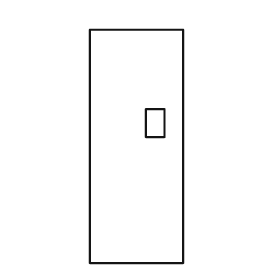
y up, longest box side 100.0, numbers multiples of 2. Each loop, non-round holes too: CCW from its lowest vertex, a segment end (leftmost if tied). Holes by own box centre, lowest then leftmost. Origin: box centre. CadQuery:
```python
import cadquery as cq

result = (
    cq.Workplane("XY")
    .moveTo(-20.0, -50.0)
    .lineTo(20.0, -50.0)
    .lineTo(20.0, 50.0)
    .lineTo(-20.0, 50.0)
    .close()
    .moveTo(4.0, 4.0)
    .lineTo(12.0, 4.0)
    .lineTo(12.0, 16.0)
    .lineTo(4.0, 16.0)
    .close()
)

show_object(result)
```